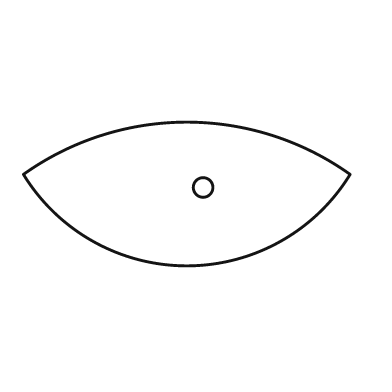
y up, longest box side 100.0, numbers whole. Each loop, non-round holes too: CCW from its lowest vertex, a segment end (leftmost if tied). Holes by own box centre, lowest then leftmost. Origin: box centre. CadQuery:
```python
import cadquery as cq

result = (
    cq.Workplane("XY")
    .moveTo(-50.0, 6.0)
    .threePointArc((0.0, -22.0), (50.0, 6.0))
    .threePointArc((0.0, 22.0), (-50.0, 6.0))
    .close()
    .moveTo(5.0, 2.0)
    .circle(3.0)
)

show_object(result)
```